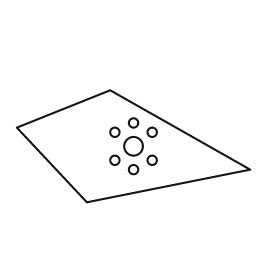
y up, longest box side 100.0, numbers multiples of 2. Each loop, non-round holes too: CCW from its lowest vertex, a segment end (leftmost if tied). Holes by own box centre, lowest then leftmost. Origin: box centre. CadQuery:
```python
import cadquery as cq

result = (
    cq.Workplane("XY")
    .moveTo(-20.0, -24.0)
    .lineTo(50.0, -10.0)
    .lineTo(-10.0, 24.0)
    .lineTo(-50.0, 8.0)
    .close()
    .moveTo(0.0, -10.0)
    .circle(2.0)
    .moveTo(-8.0, -6.0)
    .circle(2.0)
    .moveTo(8.0, -6.0)
    .circle(2.0)
    .moveTo(0.0, 0.0)
    .circle(4.0)
    .moveTo(-8.0, 6.0)
    .circle(2.0)
    .moveTo(8.0, 6.0)
    .circle(2.0)
    .moveTo(0.0, 10.0)
    .circle(2.0)
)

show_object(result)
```